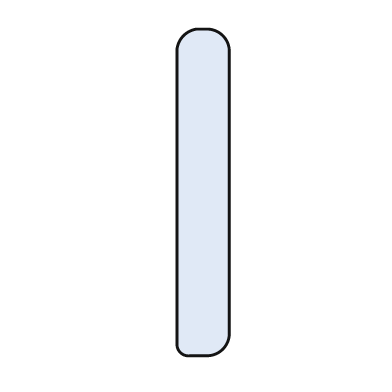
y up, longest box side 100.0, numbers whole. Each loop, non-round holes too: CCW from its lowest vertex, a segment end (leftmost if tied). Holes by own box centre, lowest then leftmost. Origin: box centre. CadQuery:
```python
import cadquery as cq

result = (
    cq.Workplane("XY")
    .moveTo(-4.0, -50.0)
    .lineTo(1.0, -50.0)
    .threePointArc((6.0, -48.0), (8.0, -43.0))
    .lineTo(8.0, 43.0)
    .threePointArc((6.0, 48.0), (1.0, 50.0))
    .lineTo(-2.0, 50.0)
    .threePointArc((-6.0, 48.0), (-8.0, 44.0))
    .lineTo(-8.0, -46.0)
    .threePointArc((-7.0, -49.0), (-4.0, -50.0))
    .close()
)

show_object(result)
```